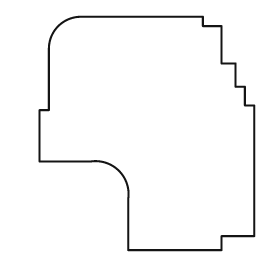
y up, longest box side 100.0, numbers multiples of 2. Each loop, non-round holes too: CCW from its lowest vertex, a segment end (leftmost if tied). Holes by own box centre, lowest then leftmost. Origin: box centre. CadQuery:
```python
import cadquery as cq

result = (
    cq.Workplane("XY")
    .moveTo(-8.0, -50.0)
    .lineTo(32.0, -50.0)
    .lineTo(32.0, -44.0)
    .lineTo(46.0, -44.0)
    .lineTo(46.0, 12.0)
    .lineTo(42.0, 12.0)
    .lineTo(42.0, 20.0)
    .lineTo(38.0, 20.0)
    .lineTo(38.0, 30.0)
    .lineTo(32.0, 30.0)
    .lineTo(32.0, 46.0)
    .lineTo(24.0, 46.0)
    .lineTo(24.0, 50.0)
    .lineTo(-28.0, 50.0)
    .threePointArc((-38.0, 46.0), (-42.0, 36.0))
    .lineTo(-42.0, 10.0)
    .lineTo(-46.0, 10.0)
    .lineTo(-46.0, -12.0)
    .lineTo(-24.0, -12.0)
    .threePointArc((-12.0, -16.0), (-8.0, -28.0))
    .close()
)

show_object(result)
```